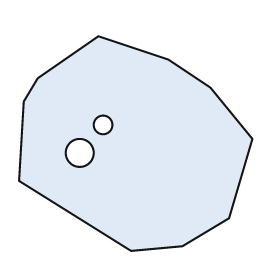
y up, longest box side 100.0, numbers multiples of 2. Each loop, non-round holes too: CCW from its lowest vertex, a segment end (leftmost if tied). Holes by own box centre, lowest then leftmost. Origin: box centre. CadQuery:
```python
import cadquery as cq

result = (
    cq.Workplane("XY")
    .moveTo(-2.0, -46.0)
    .lineTo(20.0, -44.0)
    .lineTo(40.0, -32.0)
    .lineTo(50.0, 2.0)
    .lineTo(32.0, 24.0)
    .lineTo(14.0, 36.0)
    .lineTo(-16.0, 46.0)
    .lineTo(-42.0, 28.0)
    .lineTo(-48.0, 18.0)
    .lineTo(-50.0, -16.0)
    .close()
    .moveTo(-24.0, -4.0)
    .circle(6.0)
    .moveTo(-14.0, 8.0)
    .circle(4.0)
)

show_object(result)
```